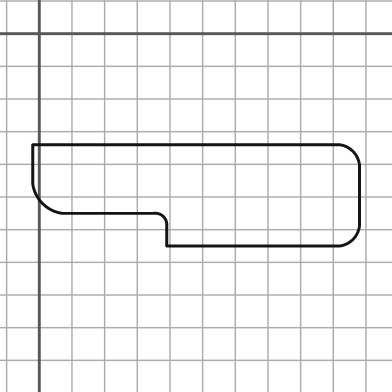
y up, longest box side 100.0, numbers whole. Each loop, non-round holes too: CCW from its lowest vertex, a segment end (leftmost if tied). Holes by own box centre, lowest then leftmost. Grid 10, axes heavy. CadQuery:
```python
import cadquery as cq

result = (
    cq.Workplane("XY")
    .moveTo(39.0, -65.0)
    .lineTo(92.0, -65.0)
    .threePointArc((96.0, -63.0), (98.0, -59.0))
    .lineTo(98.0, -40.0)
    .threePointArc((96.0, -36.0), (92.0, -34.0))
    .lineTo(-2.0, -34.0)
    .lineTo(-2.0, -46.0)
    .threePointArc((1.0, -52.0), (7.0, -55.0))
    .lineTo(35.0, -55.0)
    .threePointArc((38.0, -56.0), (39.0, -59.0))
    .close()
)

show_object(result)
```